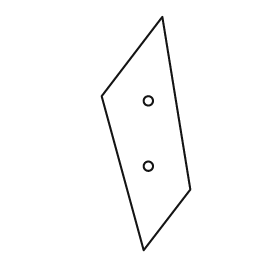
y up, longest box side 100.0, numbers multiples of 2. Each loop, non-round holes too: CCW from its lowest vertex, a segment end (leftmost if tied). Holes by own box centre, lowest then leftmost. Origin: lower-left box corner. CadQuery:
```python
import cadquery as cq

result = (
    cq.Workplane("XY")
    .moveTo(18.0, 0.0)
    .lineTo(38.0, 26.0)
    .lineTo(26.0, 100.0)
    .lineTo(0.0, 66.0)
    .close()
    .moveTo(20.0, 36.0)
    .circle(2.0)
    .moveTo(20.0, 64.0)
    .circle(2.0)
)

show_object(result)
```